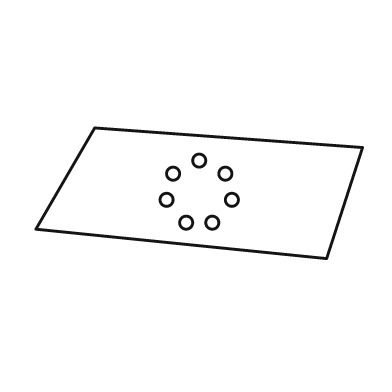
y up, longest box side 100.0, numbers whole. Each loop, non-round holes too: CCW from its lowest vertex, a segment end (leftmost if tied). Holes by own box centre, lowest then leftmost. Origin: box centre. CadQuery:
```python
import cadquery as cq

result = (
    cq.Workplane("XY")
    .moveTo(39.0, -20.0)
    .lineTo(50.0, 14.0)
    .lineTo(-32.0, 20.0)
    .lineTo(-50.0, -11.0)
    .close()
    .moveTo(-4.0, -9.0)
    .circle(2.0)
    .moveTo(4.0, -9.0)
    .circle(2.0)
    .moveTo(-10.0, -2.0)
    .circle(2.0)
    .moveTo(10.0, -2.0)
    .circle(2.0)
    .moveTo(-8.0, 6.0)
    .circle(2.0)
    .moveTo(8.0, 6.0)
    .circle(2.0)
    .moveTo(0.0, 10.0)
    .circle(2.0)
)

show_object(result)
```